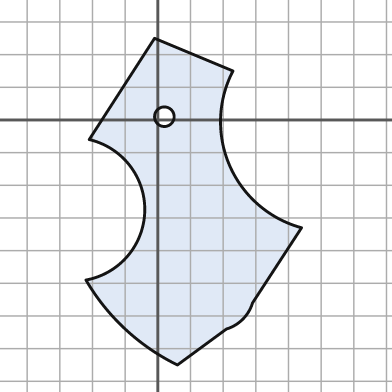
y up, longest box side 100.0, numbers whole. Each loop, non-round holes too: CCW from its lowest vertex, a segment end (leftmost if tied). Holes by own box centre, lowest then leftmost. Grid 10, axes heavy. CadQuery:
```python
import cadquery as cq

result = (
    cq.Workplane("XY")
    .moveTo(6.0, -75.0)
    .lineTo(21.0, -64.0)
    .threePointArc((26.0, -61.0), (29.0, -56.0))
    .lineTo(44.0, -33.0)
    .threePointArc((22.0, -14.0), (23.0, 15.0))
    .lineTo(-1.0, 25.0)
    .lineTo(-21.0, -6.0)
    .threePointArc((-4.0, -28.0), (-22.0, -49.0))
    .threePointArc((-10.0, -64.0), (6.0, -75.0))
    .close()
    .moveTo(2.0, 1.0)
    .circle(3.0)
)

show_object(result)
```